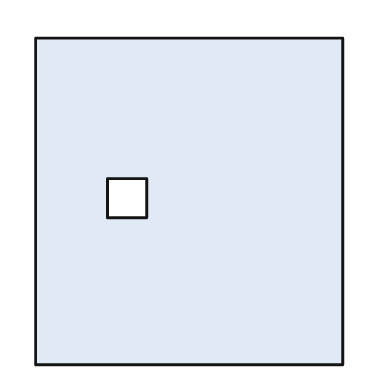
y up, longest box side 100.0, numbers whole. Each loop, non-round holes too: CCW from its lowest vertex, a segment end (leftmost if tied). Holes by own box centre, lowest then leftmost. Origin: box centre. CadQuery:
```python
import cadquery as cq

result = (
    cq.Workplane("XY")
    .moveTo(-47.0, -50.0)
    .lineTo(47.0, -50.0)
    .lineTo(47.0, 50.0)
    .lineTo(-47.0, 50.0)
    .close()
    .moveTo(-25.0, -5.0)
    .lineTo(-13.0, -5.0)
    .lineTo(-13.0, 7.0)
    .lineTo(-25.0, 7.0)
    .close()
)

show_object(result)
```